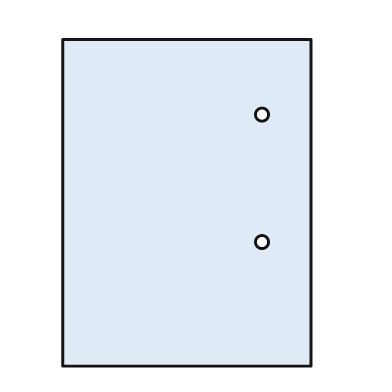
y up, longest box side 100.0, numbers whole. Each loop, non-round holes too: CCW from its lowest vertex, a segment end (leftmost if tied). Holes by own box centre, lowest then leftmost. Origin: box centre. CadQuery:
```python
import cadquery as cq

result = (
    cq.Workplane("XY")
    .moveTo(-38.0, -50.0)
    .lineTo(38.0, -50.0)
    .lineTo(38.0, 50.0)
    .lineTo(-38.0, 50.0)
    .close()
    .moveTo(23.0, -12.0)
    .circle(2.0)
    .moveTo(23.0, 27.0)
    .circle(2.0)
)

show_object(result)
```